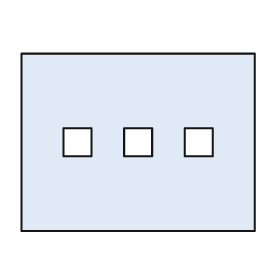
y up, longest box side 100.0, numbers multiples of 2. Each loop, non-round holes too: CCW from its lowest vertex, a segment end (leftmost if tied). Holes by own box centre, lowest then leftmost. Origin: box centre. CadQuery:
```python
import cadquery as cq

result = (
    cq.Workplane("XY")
    .moveTo(-50.0, -38.0)
    .lineTo(50.0, -38.0)
    .lineTo(50.0, 38.0)
    .lineTo(-50.0, 38.0)
    .close()
    .moveTo(-32.0, -6.0)
    .lineTo(-20.0, -6.0)
    .lineTo(-20.0, 6.0)
    .lineTo(-32.0, 6.0)
    .close()
    .moveTo(-6.0, -6.0)
    .lineTo(6.0, -6.0)
    .lineTo(6.0, 6.0)
    .lineTo(-6.0, 6.0)
    .close()
    .moveTo(20.0, -6.0)
    .lineTo(32.0, -6.0)
    .lineTo(32.0, 6.0)
    .lineTo(20.0, 6.0)
    .close()
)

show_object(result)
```